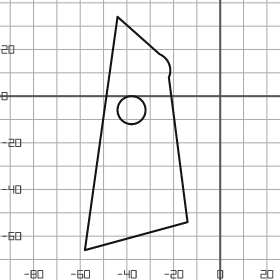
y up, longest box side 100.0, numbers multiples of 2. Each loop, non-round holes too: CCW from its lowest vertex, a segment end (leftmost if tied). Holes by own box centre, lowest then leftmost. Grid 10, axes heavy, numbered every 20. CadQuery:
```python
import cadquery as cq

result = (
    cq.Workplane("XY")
    .moveTo(-58.0, -66.0)
    .lineTo(-14.0, -54.0)
    .lineTo(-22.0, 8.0)
    .threePointArc((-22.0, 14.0), (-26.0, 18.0))
    .lineTo(-44.0, 34.0)
    .close()
    .moveTo(-38.0, -6.0)
    .circle(6.0)
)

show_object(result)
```